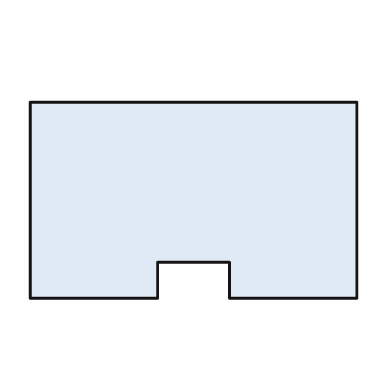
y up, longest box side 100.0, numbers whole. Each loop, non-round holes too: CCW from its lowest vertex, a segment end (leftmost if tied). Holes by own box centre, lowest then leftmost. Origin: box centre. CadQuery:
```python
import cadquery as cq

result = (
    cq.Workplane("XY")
    .moveTo(-50.0, -30.0)
    .lineTo(-11.0, -30.0)
    .lineTo(-11.0, -19.0)
    .lineTo(11.0, -19.0)
    .lineTo(11.0, -30.0)
    .lineTo(50.0, -30.0)
    .lineTo(50.0, 30.0)
    .lineTo(-50.0, 30.0)
    .close()
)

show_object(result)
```